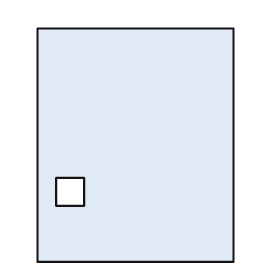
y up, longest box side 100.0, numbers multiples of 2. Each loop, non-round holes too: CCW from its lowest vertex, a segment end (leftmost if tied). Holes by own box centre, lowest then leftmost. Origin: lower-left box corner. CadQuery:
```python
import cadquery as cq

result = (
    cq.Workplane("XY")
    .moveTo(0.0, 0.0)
    .lineTo(84.0, 0.0)
    .lineTo(84.0, 100.0)
    .lineTo(0.0, 100.0)
    .close()
    .moveTo(8.0, 24.0)
    .lineTo(20.0, 24.0)
    .lineTo(20.0, 36.0)
    .lineTo(8.0, 36.0)
    .close()
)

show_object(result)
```